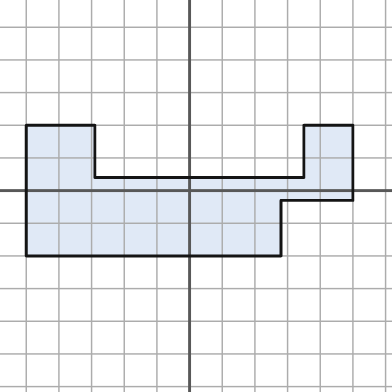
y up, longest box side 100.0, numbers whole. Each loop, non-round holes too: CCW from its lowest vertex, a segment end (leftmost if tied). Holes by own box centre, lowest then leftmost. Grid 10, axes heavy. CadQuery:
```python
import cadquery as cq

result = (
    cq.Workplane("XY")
    .moveTo(-50.0, -20.0)
    .lineTo(28.0, -20.0)
    .lineTo(28.0, -3.0)
    .lineTo(50.0, -3.0)
    .lineTo(50.0, 20.0)
    .lineTo(35.0, 20.0)
    .lineTo(35.0, 4.0)
    .lineTo(-29.0, 4.0)
    .lineTo(-29.0, 20.0)
    .lineTo(-50.0, 20.0)
    .close()
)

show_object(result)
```